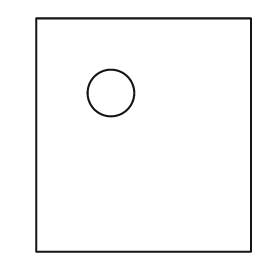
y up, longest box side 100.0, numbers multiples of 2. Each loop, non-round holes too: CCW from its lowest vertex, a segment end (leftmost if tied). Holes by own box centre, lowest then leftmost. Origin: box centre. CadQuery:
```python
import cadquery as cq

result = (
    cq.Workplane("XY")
    .moveTo(-46.0, -50.0)
    .lineTo(46.0, -50.0)
    .lineTo(46.0, 50.0)
    .lineTo(-46.0, 50.0)
    .close()
    .moveTo(-14.0, 18.0)
    .circle(10.0)
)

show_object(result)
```